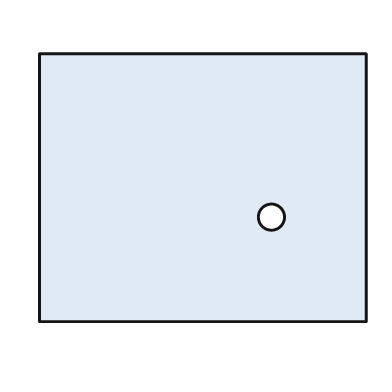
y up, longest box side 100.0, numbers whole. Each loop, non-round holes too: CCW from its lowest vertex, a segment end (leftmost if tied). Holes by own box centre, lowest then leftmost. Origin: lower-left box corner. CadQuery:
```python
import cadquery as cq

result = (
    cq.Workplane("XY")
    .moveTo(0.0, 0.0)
    .lineTo(100.0, 0.0)
    .lineTo(100.0, 82.0)
    .lineTo(0.0, 82.0)
    .close()
    .moveTo(71.0, 32.0)
    .circle(4.0)
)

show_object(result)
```